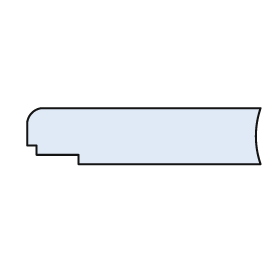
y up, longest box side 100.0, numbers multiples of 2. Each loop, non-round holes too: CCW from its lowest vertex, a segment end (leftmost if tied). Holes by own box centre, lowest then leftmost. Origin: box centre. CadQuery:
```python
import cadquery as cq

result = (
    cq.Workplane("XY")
    .moveTo(-28.0, -12.0)
    .lineTo(50.0, -12.0)
    .threePointArc((48.0, 0.0), (50.0, 12.0))
    .lineTo(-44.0, 12.0)
    .threePointArc((-48.0, 10.0), (-50.0, 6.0))
    .lineTo(-50.0, -4.0)
    .lineTo(-46.0, -4.0)
    .lineTo(-46.0, -8.0)
    .lineTo(-28.0, -8.0)
    .close()
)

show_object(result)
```